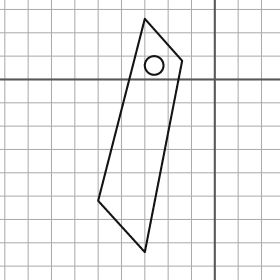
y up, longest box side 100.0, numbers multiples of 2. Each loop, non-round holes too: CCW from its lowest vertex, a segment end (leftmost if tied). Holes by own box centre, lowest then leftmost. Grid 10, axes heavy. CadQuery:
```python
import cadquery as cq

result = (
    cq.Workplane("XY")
    .moveTo(-30.0, -74.0)
    .lineTo(-14.0, 8.0)
    .lineTo(-30.0, 26.0)
    .lineTo(-50.0, -52.0)
    .close()
    .moveTo(-26.0, 6.0)
    .circle(4.0)
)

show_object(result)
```